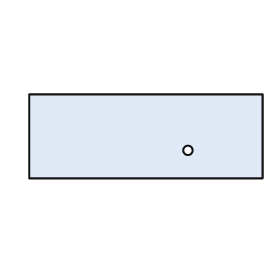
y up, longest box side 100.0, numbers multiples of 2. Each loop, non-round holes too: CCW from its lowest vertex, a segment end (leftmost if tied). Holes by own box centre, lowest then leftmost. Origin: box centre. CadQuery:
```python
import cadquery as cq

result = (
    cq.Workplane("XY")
    .moveTo(-50.0, -18.0)
    .lineTo(50.0, -18.0)
    .lineTo(50.0, 18.0)
    .lineTo(-50.0, 18.0)
    .close()
    .moveTo(18.0, -6.0)
    .circle(2.0)
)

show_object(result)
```